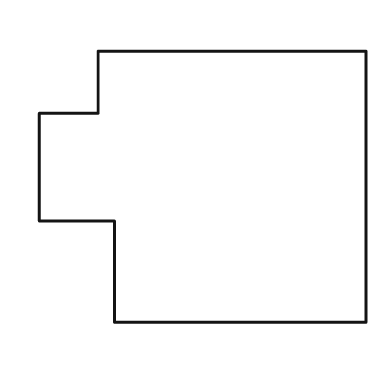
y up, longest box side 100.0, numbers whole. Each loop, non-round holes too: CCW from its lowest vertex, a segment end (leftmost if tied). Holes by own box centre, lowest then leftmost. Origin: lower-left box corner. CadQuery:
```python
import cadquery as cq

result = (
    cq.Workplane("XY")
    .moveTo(23.0, 0.0)
    .lineTo(100.0, 0.0)
    .lineTo(100.0, 83.0)
    .lineTo(18.0, 83.0)
    .lineTo(18.0, 64.0)
    .lineTo(0.0, 64.0)
    .lineTo(0.0, 31.0)
    .lineTo(23.0, 31.0)
    .close()
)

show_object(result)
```